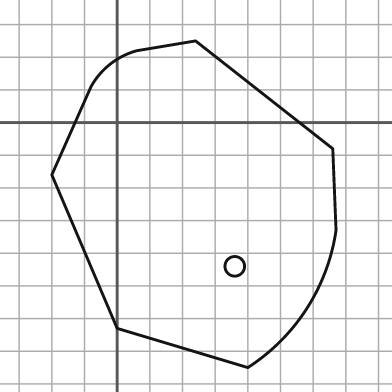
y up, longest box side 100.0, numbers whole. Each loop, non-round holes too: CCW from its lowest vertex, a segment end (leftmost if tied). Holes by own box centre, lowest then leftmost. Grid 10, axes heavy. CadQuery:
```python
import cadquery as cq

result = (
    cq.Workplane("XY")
    .moveTo(40.0, -75.0)
    .threePointArc((58.0, -57.0), (67.0, -33.0))
    .lineTo(66.0, -8.0)
    .lineTo(24.0, 25.0)
    .lineTo(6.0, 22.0)
    .threePointArc((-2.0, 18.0), (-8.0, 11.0))
    .lineTo(-20.0, -16.0)
    .lineTo(0.0, -63.0)
    .close()
    .moveTo(36.0, -44.0)
    .circle(3.0)
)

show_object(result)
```